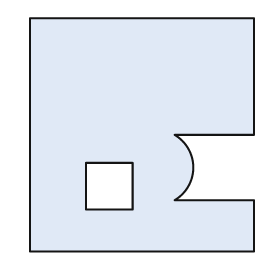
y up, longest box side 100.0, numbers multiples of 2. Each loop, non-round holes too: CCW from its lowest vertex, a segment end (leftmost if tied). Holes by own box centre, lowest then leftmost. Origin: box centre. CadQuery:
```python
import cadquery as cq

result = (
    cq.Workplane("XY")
    .moveTo(-48.0, -50.0)
    .lineTo(48.0, -50.0)
    .lineTo(48.0, -28.0)
    .lineTo(14.0, -28.0)
    .threePointArc((22.0, -14.0), (14.0, 0.0))
    .lineTo(48.0, 0.0)
    .lineTo(48.0, 50.0)
    .lineTo(-48.0, 50.0)
    .close()
    .moveTo(-24.0, -32.0)
    .lineTo(-4.0, -32.0)
    .lineTo(-4.0, -12.0)
    .lineTo(-24.0, -12.0)
    .close()
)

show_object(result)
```